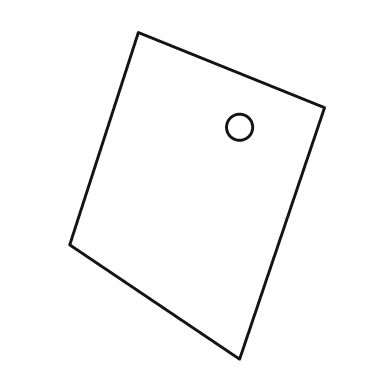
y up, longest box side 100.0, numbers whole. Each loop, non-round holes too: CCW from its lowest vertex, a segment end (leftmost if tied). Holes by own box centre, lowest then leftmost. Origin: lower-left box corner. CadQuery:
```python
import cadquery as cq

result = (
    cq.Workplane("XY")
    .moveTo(52.0, 0.0)
    .lineTo(78.0, 77.0)
    .lineTo(21.0, 100.0)
    .lineTo(0.0, 35.0)
    .close()
    .moveTo(52.0, 71.0)
    .circle(4.0)
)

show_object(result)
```